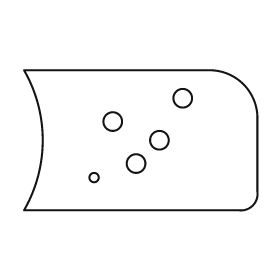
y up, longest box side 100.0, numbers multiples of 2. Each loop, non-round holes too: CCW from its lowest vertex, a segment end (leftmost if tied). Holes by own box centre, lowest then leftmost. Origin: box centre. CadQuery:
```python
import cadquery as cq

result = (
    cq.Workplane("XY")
    .moveTo(-50.0, -30.0)
    .lineTo(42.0, -30.0)
    .threePointArc((48.0, -28.0), (50.0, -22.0))
    .lineTo(50.0, 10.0)
    .threePointArc((44.0, 24.0), (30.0, 30.0))
    .lineTo(-50.0, 30.0)
    .threePointArc((-42.0, 0.0), (-50.0, -30.0))
    .close()
    .moveTo(-20.0, -16.0)
    .circle(2.0)
    .moveTo(-2.0, -10.0)
    .circle(4.0)
    .moveTo(8.0, 0.0)
    .circle(4.0)
    .moveTo(-12.0, 8.0)
    .circle(4.0)
    .moveTo(18.0, 18.0)
    .circle(4.0)
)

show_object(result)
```